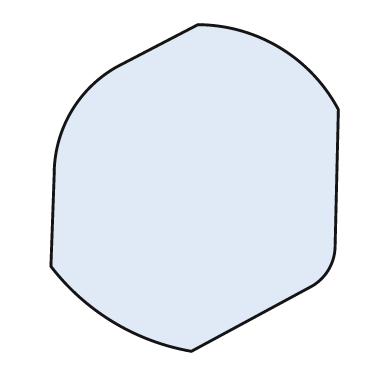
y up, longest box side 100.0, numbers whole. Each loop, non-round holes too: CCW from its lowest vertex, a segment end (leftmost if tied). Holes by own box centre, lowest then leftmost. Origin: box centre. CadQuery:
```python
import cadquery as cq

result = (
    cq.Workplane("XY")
    .moveTo(-1.0, -50.0)
    .lineTo(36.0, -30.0)
    .threePointArc((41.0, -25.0), (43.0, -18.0))
    .lineTo(44.0, 24.0)
    .threePointArc((26.0, 43.0), (1.0, 50.0))
    .lineTo(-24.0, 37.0)
    .threePointArc((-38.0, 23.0), (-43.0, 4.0))
    .lineTo(-44.0, -24.0)
    .threePointArc((-25.0, -41.0), (-1.0, -50.0))
    .close()
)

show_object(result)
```